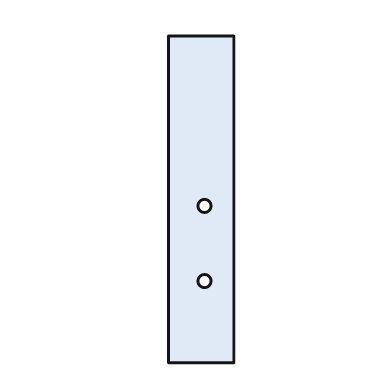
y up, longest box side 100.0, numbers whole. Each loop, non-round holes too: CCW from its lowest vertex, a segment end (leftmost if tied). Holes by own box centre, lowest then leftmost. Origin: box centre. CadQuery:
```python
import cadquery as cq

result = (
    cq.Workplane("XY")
    .moveTo(-10.0, -50.0)
    .lineTo(10.0, -50.0)
    .lineTo(10.0, 50.0)
    .lineTo(-10.0, 50.0)
    .close()
    .moveTo(1.0, -25.0)
    .circle(2.0)
    .moveTo(1.0, -2.0)
    .circle(2.0)
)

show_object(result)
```